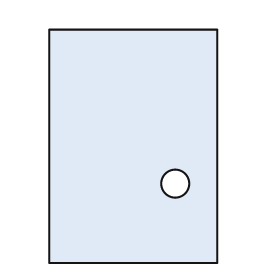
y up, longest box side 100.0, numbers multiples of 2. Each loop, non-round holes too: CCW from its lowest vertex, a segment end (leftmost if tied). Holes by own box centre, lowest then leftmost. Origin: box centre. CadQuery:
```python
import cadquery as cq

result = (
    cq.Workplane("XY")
    .moveTo(-36.0, -50.0)
    .lineTo(36.0, -50.0)
    .lineTo(36.0, 50.0)
    .lineTo(-36.0, 50.0)
    .close()
    .moveTo(18.0, -16.0)
    .circle(6.0)
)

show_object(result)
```